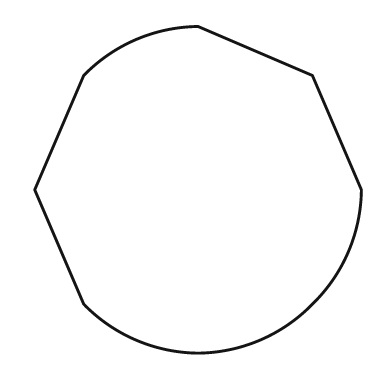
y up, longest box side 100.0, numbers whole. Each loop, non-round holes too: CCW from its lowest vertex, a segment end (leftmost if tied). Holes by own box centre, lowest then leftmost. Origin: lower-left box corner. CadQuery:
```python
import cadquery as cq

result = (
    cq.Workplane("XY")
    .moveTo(50.0, 0.0)
    .threePointArc((69.0, 4.0), (85.0, 15.0))
    .threePointArc((96.0, 31.0), (100.0, 50.0))
    .lineTo(85.0, 85.0)
    .lineTo(50.0, 100.0)
    .threePointArc((31.0, 96.0), (15.0, 85.0))
    .lineTo(0.0, 50.0)
    .lineTo(15.0, 15.0)
    .threePointArc((31.0, 4.0), (50.0, 0.0))
    .close()
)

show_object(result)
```